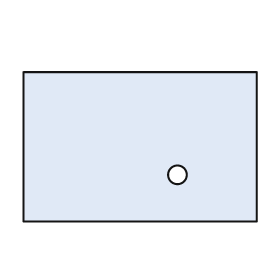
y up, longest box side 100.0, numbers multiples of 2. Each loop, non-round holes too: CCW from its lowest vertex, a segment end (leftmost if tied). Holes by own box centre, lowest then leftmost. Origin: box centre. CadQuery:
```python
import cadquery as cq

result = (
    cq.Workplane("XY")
    .moveTo(-50.0, -32.0)
    .lineTo(50.0, -32.0)
    .lineTo(50.0, 32.0)
    .lineTo(-50.0, 32.0)
    .close()
    .moveTo(16.0, -12.0)
    .circle(4.0)
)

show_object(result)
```